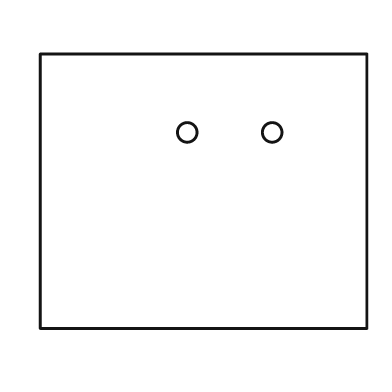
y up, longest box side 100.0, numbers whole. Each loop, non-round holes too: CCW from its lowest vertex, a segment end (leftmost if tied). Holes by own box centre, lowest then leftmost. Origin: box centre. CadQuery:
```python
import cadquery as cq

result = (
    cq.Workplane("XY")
    .moveTo(-50.0, -42.0)
    .lineTo(50.0, -42.0)
    .lineTo(50.0, 42.0)
    .lineTo(-50.0, 42.0)
    .close()
    .moveTo(-5.0, 18.0)
    .circle(3.0)
    .moveTo(21.0, 18.0)
    .circle(3.0)
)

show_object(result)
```